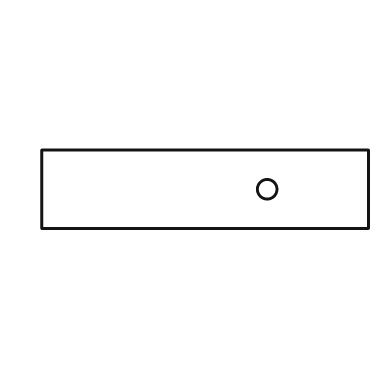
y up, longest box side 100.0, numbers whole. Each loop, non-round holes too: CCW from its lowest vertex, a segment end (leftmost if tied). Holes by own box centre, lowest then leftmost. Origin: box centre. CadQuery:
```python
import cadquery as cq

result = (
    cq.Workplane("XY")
    .moveTo(-50.0, -12.0)
    .lineTo(50.0, -12.0)
    .lineTo(50.0, 12.0)
    .lineTo(-50.0, 12.0)
    .close()
    .moveTo(19.0, 0.0)
    .circle(3.0)
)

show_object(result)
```